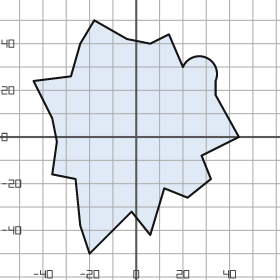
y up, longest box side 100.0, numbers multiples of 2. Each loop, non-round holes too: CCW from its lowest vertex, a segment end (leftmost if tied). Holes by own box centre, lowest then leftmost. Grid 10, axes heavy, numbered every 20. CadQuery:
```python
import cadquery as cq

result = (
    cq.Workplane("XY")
    .moveTo(-20.0, -50.0)
    .lineTo(-2.0, -32.0)
    .lineTo(6.0, -42.0)
    .lineTo(12.0, -22.0)
    .lineTo(22.0, -26.0)
    .lineTo(32.0, -18.0)
    .lineTo(28.0, -8.0)
    .lineTo(44.0, 0.0)
    .lineTo(34.0, 18.0)
    .lineTo(34.0, 24.0)
    .threePointArc((30.0, 34.0), (20.0, 30.0))
    .lineTo(14.0, 44.0)
    .lineTo(6.0, 40.0)
    .lineTo(-4.0, 42.0)
    .lineTo(-18.0, 50.0)
    .lineTo(-24.0, 40.0)
    .lineTo(-28.0, 26.0)
    .lineTo(-44.0, 24.0)
    .lineTo(-36.0, 8.0)
    .lineTo(-34.0, -2.0)
    .lineTo(-36.0, -16.0)
    .lineTo(-26.0, -18.0)
    .lineTo(-24.0, -38.0)
    .close()
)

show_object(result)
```